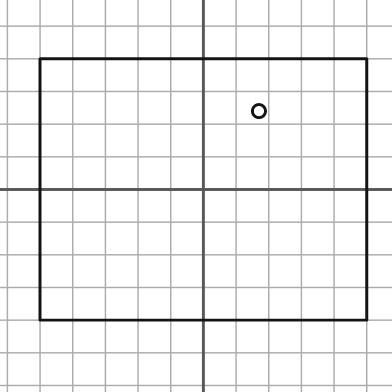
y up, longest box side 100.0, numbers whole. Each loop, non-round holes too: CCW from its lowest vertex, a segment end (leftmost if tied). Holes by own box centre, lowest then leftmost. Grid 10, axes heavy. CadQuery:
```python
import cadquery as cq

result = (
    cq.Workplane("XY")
    .moveTo(-50.0, -40.0)
    .lineTo(50.0, -40.0)
    .lineTo(50.0, 40.0)
    .lineTo(-50.0, 40.0)
    .close()
    .moveTo(17.0, 24.0)
    .circle(2.0)
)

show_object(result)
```